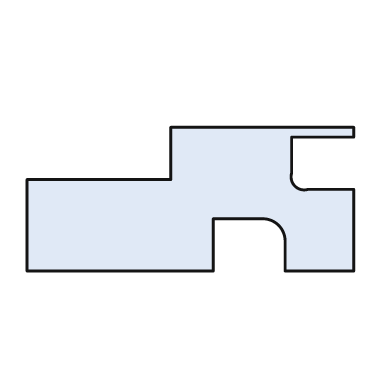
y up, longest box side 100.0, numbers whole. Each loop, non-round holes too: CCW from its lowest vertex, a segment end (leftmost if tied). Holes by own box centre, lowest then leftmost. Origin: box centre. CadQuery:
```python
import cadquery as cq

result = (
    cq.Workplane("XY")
    .moveTo(-50.0, -22.0)
    .lineTo(7.0, -22.0)
    .lineTo(7.0, -6.0)
    .lineTo(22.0, -6.0)
    .threePointArc((27.0, -8.0), (29.0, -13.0))
    .lineTo(29.0, -22.0)
    .lineTo(50.0, -22.0)
    .lineTo(50.0, 3.0)
    .lineTo(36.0, 3.0)
    .threePointArc((32.0, 4.0), (31.0, 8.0))
    .lineTo(31.0, 19.0)
    .lineTo(50.0, 19.0)
    .lineTo(50.0, 22.0)
    .lineTo(-6.0, 22.0)
    .lineTo(-6.0, 6.0)
    .lineTo(-50.0, 6.0)
    .close()
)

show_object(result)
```